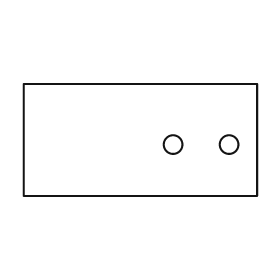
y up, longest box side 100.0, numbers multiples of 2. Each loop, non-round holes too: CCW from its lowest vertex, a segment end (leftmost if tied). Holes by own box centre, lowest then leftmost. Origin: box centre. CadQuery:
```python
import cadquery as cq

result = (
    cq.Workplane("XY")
    .moveTo(-50.0, -24.0)
    .lineTo(50.0, -24.0)
    .lineTo(50.0, 24.0)
    .lineTo(-50.0, 24.0)
    .close()
    .moveTo(14.0, -2.0)
    .circle(4.0)
    .moveTo(38.0, -2.0)
    .circle(4.0)
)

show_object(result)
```